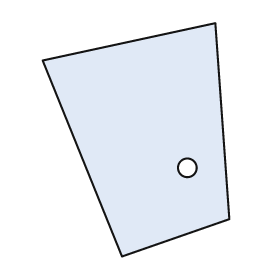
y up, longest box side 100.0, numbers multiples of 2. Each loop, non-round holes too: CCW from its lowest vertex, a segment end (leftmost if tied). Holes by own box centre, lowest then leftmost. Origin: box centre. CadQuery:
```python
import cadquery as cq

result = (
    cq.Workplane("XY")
    .moveTo(-6.0, -50.0)
    .lineTo(40.0, -34.0)
    .lineTo(34.0, 50.0)
    .lineTo(-40.0, 34.0)
    .close()
    .moveTo(22.0, -12.0)
    .circle(4.0)
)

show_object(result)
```